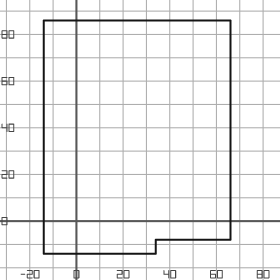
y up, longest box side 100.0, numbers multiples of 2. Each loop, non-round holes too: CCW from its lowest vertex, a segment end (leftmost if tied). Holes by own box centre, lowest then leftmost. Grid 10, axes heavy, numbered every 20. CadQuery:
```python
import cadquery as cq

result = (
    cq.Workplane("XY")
    .moveTo(-14.0, -14.0)
    .lineTo(34.0, -14.0)
    .lineTo(34.0, -8.0)
    .lineTo(66.0, -8.0)
    .lineTo(66.0, 86.0)
    .lineTo(-14.0, 86.0)
    .close()
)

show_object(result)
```